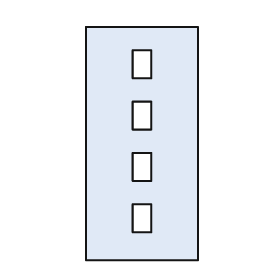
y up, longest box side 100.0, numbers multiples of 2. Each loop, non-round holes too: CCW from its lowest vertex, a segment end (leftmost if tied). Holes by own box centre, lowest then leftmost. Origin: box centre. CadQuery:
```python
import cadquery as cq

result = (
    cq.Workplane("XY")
    .moveTo(-24.0, -50.0)
    .lineTo(24.0, -50.0)
    .lineTo(24.0, 50.0)
    .lineTo(-24.0, 50.0)
    .close()
    .moveTo(-4.0, -38.0)
    .lineTo(4.0, -38.0)
    .lineTo(4.0, -26.0)
    .lineTo(-4.0, -26.0)
    .close()
    .moveTo(-4.0, -16.0)
    .lineTo(4.0, -16.0)
    .lineTo(4.0, -4.0)
    .lineTo(-4.0, -4.0)
    .close()
    .moveTo(-4.0, 6.0)
    .lineTo(4.0, 6.0)
    .lineTo(4.0, 18.0)
    .lineTo(-4.0, 18.0)
    .close()
    .moveTo(-4.0, 28.0)
    .lineTo(4.0, 28.0)
    .lineTo(4.0, 40.0)
    .lineTo(-4.0, 40.0)
    .close()
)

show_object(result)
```